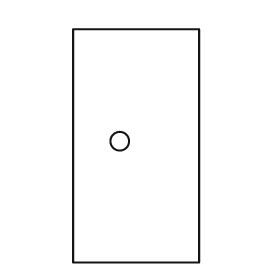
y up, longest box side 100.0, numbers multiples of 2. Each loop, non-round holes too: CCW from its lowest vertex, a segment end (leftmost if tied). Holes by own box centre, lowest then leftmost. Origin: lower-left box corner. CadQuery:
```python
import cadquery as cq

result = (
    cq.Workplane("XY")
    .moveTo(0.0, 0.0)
    .lineTo(54.0, 0.0)
    .lineTo(54.0, 100.0)
    .lineTo(0.0, 100.0)
    .close()
    .moveTo(20.0, 52.0)
    .circle(4.0)
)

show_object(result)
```